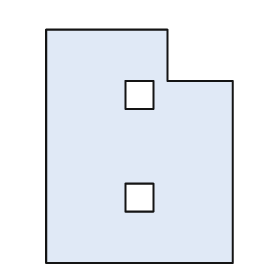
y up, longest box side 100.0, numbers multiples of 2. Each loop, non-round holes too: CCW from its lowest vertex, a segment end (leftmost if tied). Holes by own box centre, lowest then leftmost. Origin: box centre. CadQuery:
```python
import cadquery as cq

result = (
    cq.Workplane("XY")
    .moveTo(-40.0, -50.0)
    .lineTo(40.0, -50.0)
    .lineTo(40.0, 28.0)
    .lineTo(12.0, 28.0)
    .lineTo(12.0, 50.0)
    .lineTo(-40.0, 50.0)
    .close()
    .moveTo(-6.0, -28.0)
    .lineTo(6.0, -28.0)
    .lineTo(6.0, -16.0)
    .lineTo(-6.0, -16.0)
    .close()
    .moveTo(-6.0, 16.0)
    .lineTo(6.0, 16.0)
    .lineTo(6.0, 28.0)
    .lineTo(-6.0, 28.0)
    .close()
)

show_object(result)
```